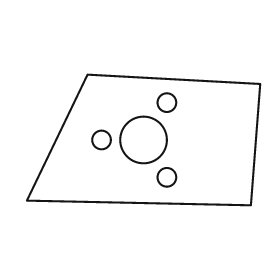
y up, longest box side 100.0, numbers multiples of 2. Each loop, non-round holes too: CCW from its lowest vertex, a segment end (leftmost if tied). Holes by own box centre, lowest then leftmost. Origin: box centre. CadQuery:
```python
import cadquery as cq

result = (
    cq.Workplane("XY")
    .moveTo(46.0, -28.0)
    .lineTo(50.0, 24.0)
    .lineTo(-24.0, 28.0)
    .lineTo(-50.0, -26.0)
    .close()
    .moveTo(10.0, -16.0)
    .circle(4.0)
    .moveTo(-18.0, 0.0)
    .circle(4.0)
    .moveTo(0.0, 0.0)
    .circle(10.0)
    .moveTo(10.0, 16.0)
    .circle(4.0)
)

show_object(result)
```